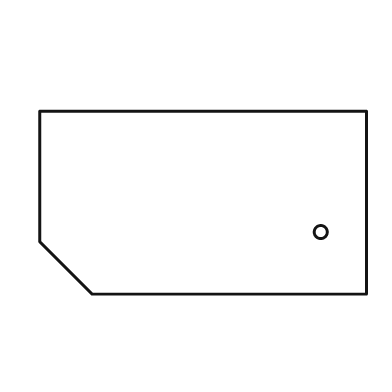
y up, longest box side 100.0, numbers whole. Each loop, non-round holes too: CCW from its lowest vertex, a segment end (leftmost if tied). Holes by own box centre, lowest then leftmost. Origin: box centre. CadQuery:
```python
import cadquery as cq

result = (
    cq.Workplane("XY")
    .moveTo(-34.0, -28.0)
    .lineTo(50.0, -28.0)
    .lineTo(50.0, 28.0)
    .lineTo(-50.0, 28.0)
    .lineTo(-50.0, -12.0)
    .close()
    .moveTo(36.0, -9.0)
    .circle(2.0)
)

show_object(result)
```